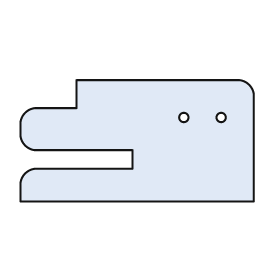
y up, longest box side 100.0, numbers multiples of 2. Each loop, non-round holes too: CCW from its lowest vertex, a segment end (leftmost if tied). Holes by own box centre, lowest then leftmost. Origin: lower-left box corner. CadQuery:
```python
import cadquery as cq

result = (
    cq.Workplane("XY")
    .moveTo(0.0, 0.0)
    .lineTo(100.0, 0.0)
    .lineTo(100.0, 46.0)
    .threePointArc((98.0, 50.0), (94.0, 52.0))
    .lineTo(24.0, 52.0)
    .lineTo(24.0, 40.0)
    .lineTo(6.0, 40.0)
    .threePointArc((2.0, 38.0), (0.0, 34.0))
    .lineTo(0.0, 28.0)
    .threePointArc((2.0, 24.0), (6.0, 22.0))
    .lineTo(48.0, 22.0)
    .lineTo(48.0, 14.0)
    .lineTo(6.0, 14.0)
    .threePointArc((2.0, 12.0), (0.0, 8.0))
    .close()
    .moveTo(70.0, 36.0)
    .circle(2.0)
    .moveTo(86.0, 36.0)
    .circle(2.0)
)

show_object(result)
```